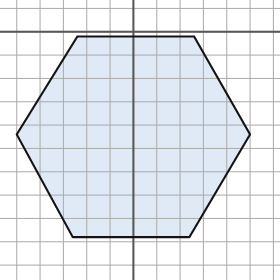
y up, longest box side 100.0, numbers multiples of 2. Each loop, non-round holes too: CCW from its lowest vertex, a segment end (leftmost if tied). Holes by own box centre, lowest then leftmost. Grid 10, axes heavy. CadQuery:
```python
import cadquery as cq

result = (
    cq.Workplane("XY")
    .moveTo(-26.0, -88.0)
    .lineTo(24.0, -88.0)
    .lineTo(50.0, -44.0)
    .lineTo(26.0, -2.0)
    .lineTo(-24.0, -2.0)
    .lineTo(-50.0, -44.0)
    .close()
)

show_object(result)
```